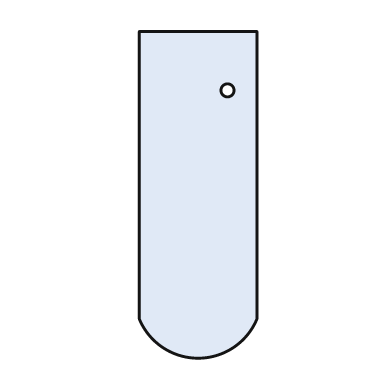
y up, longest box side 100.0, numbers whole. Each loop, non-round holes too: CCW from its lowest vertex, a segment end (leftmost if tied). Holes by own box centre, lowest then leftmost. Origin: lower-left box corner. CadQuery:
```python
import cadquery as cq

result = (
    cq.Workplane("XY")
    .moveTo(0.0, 12.0)
    .threePointArc((18.0, 0.0), (36.0, 12.0))
    .lineTo(36.0, 100.0)
    .lineTo(0.0, 100.0)
    .close()
    .moveTo(27.0, 82.0)
    .circle(2.0)
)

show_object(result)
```